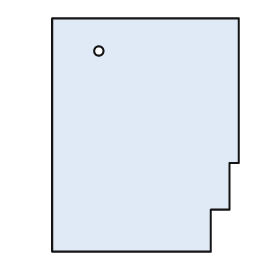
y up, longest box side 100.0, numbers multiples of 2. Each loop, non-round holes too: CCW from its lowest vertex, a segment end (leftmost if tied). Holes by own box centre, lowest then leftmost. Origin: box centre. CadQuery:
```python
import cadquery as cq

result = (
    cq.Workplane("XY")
    .moveTo(-40.0, -50.0)
    .lineTo(28.0, -50.0)
    .lineTo(28.0, -32.0)
    .lineTo(36.0, -32.0)
    .lineTo(36.0, -12.0)
    .lineTo(40.0, -12.0)
    .lineTo(40.0, 50.0)
    .lineTo(-40.0, 50.0)
    .close()
    .moveTo(-20.0, 36.0)
    .circle(2.0)
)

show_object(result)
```